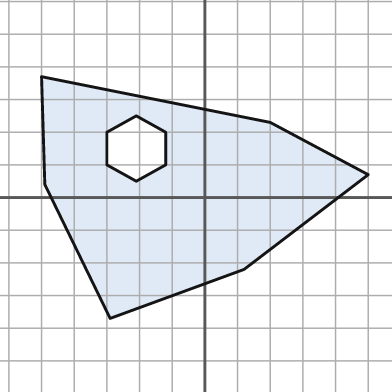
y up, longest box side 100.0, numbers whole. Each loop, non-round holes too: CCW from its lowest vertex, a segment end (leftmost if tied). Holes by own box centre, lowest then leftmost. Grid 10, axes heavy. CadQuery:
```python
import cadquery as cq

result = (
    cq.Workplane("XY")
    .moveTo(-29.0, -37.0)
    .lineTo(12.0, -22.0)
    .lineTo(50.0, 7.0)
    .lineTo(20.0, 23.0)
    .lineTo(-50.0, 37.0)
    .lineTo(-49.0, 4.0)
    .close()
    .moveTo(-21.0, 5.0)
    .lineTo(-12.0, 10.0)
    .lineTo(-12.0, 20.0)
    .lineTo(-21.0, 25.0)
    .lineTo(-30.0, 20.0)
    .lineTo(-30.0, 10.0)
    .close()
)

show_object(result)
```